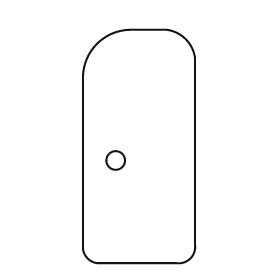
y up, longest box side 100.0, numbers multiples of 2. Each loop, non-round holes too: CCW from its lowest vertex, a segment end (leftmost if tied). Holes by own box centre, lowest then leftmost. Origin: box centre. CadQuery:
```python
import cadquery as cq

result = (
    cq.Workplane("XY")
    .moveTo(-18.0, -50.0)
    .lineTo(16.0, -50.0)
    .threePointArc((22.0, -48.0), (24.0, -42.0))
    .lineTo(24.0, 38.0)
    .threePointArc((20.0, 46.0), (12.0, 50.0))
    .lineTo(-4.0, 50.0)
    .threePointArc((-18.0, 44.0), (-24.0, 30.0))
    .lineTo(-24.0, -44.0)
    .threePointArc((-22.0, -48.0), (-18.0, -50.0))
    .close()
    .moveTo(-10.0, -6.0)
    .circle(4.0)
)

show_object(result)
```